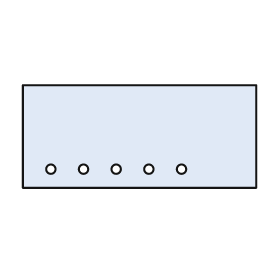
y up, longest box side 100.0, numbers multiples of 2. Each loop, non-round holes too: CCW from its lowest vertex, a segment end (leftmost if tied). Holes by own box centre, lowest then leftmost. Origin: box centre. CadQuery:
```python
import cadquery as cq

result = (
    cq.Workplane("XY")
    .moveTo(-50.0, -22.0)
    .lineTo(50.0, -22.0)
    .lineTo(50.0, 22.0)
    .lineTo(-50.0, 22.0)
    .close()
    .moveTo(-38.0, -14.0)
    .circle(2.0)
    .moveTo(-24.0, -14.0)
    .circle(2.0)
    .moveTo(-10.0, -14.0)
    .circle(2.0)
    .moveTo(4.0, -14.0)
    .circle(2.0)
    .moveTo(18.0, -14.0)
    .circle(2.0)
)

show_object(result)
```